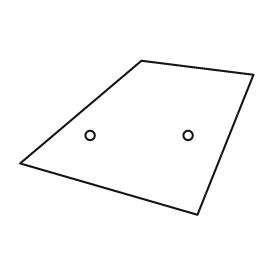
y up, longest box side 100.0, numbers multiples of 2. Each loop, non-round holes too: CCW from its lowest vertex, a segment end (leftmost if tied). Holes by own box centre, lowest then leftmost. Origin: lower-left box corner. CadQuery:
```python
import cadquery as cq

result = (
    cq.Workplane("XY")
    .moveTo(76.0, 0.0)
    .lineTo(100.0, 60.0)
    .lineTo(52.0, 66.0)
    .lineTo(0.0, 22.0)
    .close()
    .moveTo(30.0, 34.0)
    .circle(2.0)
    .moveTo(72.0, 34.0)
    .circle(2.0)
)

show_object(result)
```